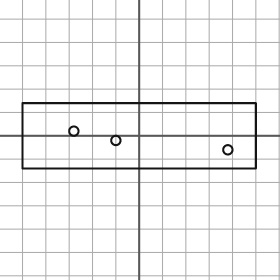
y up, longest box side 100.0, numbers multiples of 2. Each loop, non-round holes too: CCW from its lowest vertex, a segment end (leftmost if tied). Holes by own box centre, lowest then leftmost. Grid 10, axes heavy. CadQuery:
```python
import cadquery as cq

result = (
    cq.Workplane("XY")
    .moveTo(-50.0, -14.0)
    .lineTo(50.0, -14.0)
    .lineTo(50.0, 14.0)
    .lineTo(-50.0, 14.0)
    .close()
    .moveTo(38.0, -6.0)
    .circle(2.0)
    .moveTo(-10.0, -2.0)
    .circle(2.0)
    .moveTo(-28.0, 2.0)
    .circle(2.0)
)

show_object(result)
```